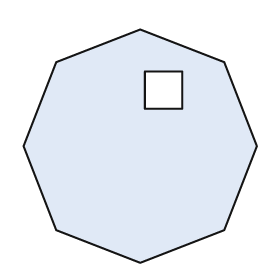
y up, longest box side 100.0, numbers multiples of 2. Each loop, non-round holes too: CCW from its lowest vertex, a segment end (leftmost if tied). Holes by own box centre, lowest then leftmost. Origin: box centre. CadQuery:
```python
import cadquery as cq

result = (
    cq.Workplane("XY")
    .moveTo(0.0, -50.0)
    .lineTo(36.0, -36.0)
    .lineTo(50.0, 0.0)
    .lineTo(36.0, 36.0)
    .lineTo(0.0, 50.0)
    .lineTo(-36.0, 36.0)
    .lineTo(-50.0, 0.0)
    .lineTo(-36.0, -36.0)
    .close()
    .moveTo(2.0, 16.0)
    .lineTo(18.0, 16.0)
    .lineTo(18.0, 32.0)
    .lineTo(2.0, 32.0)
    .close()
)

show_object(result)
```